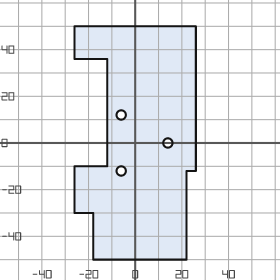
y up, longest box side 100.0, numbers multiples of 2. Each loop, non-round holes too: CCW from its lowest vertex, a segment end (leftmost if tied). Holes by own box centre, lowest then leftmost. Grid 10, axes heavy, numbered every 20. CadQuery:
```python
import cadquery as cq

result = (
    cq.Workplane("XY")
    .moveTo(-18.0, -50.0)
    .lineTo(22.0, -50.0)
    .lineTo(22.0, -12.0)
    .lineTo(26.0, -12.0)
    .lineTo(26.0, 50.0)
    .lineTo(-26.0, 50.0)
    .lineTo(-26.0, 36.0)
    .lineTo(-12.0, 36.0)
    .lineTo(-12.0, -10.0)
    .lineTo(-26.0, -10.0)
    .lineTo(-26.0, -30.0)
    .lineTo(-18.0, -30.0)
    .close()
    .moveTo(-6.0, -12.0)
    .circle(2.0)
    .moveTo(14.0, 0.0)
    .circle(2.0)
    .moveTo(-6.0, 12.0)
    .circle(2.0)
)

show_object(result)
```